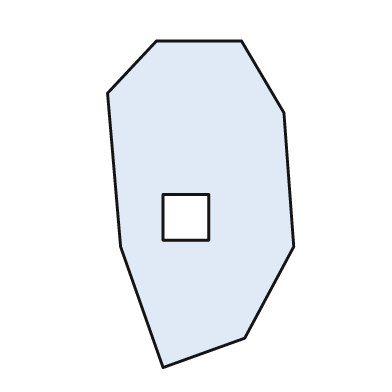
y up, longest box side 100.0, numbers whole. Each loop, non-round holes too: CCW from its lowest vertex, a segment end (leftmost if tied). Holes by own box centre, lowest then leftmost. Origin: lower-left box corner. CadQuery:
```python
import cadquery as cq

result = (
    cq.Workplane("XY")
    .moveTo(17.0, 0.0)
    .lineTo(42.0, 9.0)
    .lineTo(57.0, 37.0)
    .lineTo(54.0, 78.0)
    .lineTo(41.0, 100.0)
    .lineTo(15.0, 100.0)
    .lineTo(0.0, 84.0)
    .lineTo(4.0, 37.0)
    .close()
    .moveTo(17.0, 39.0)
    .lineTo(31.0, 39.0)
    .lineTo(31.0, 53.0)
    .lineTo(17.0, 53.0)
    .close()
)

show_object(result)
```